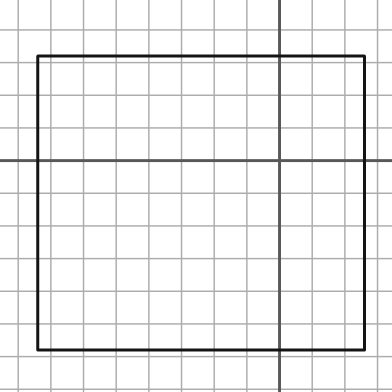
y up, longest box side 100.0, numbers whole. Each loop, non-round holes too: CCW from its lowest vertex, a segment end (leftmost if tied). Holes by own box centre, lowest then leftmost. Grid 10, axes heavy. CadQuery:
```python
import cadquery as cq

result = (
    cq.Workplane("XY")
    .moveTo(-74.0, -58.0)
    .lineTo(26.0, -58.0)
    .lineTo(26.0, 32.0)
    .lineTo(-74.0, 32.0)
    .close()
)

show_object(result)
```